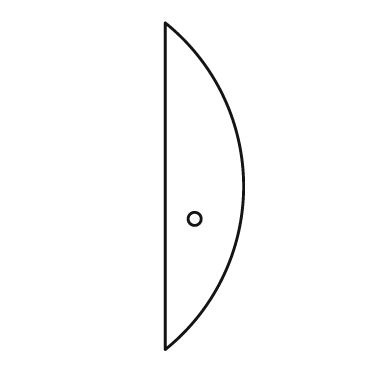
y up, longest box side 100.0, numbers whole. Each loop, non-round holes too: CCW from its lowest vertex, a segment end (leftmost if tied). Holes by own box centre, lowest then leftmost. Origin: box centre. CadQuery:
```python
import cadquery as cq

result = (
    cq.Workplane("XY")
    .moveTo(-12.0, -50.0)
    .threePointArc((12.0, 0.0), (-12.0, 50.0))
    .close()
    .moveTo(-3.0, -10.0)
    .circle(2.0)
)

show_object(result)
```